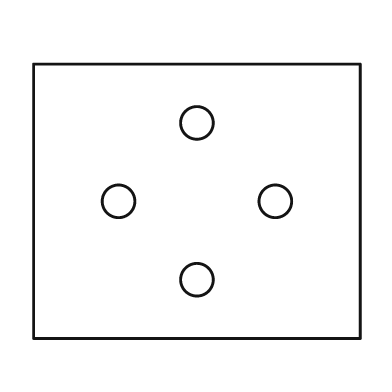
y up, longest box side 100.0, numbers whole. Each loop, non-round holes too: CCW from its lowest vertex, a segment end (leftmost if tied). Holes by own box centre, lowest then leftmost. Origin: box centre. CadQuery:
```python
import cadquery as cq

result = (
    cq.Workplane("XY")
    .moveTo(-50.0, -42.0)
    .lineTo(50.0, -42.0)
    .lineTo(50.0, 42.0)
    .lineTo(-50.0, 42.0)
    .close()
    .moveTo(0.0, -24.0)
    .circle(5.0)
    .moveTo(-24.0, 0.0)
    .circle(5.0)
    .moveTo(24.0, 0.0)
    .circle(5.0)
    .moveTo(0.0, 24.0)
    .circle(5.0)
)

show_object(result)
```